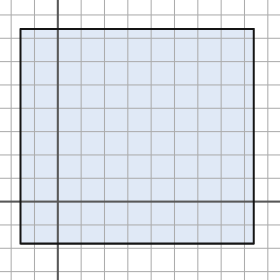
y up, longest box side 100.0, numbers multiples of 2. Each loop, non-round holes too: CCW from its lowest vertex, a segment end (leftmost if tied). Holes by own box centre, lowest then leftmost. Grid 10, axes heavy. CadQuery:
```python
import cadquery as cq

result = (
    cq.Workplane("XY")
    .moveTo(-16.0, -18.0)
    .lineTo(84.0, -18.0)
    .lineTo(84.0, 74.0)
    .lineTo(-16.0, 74.0)
    .close()
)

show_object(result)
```